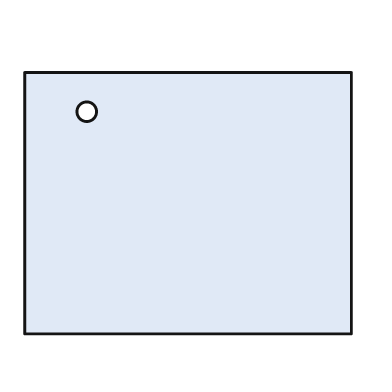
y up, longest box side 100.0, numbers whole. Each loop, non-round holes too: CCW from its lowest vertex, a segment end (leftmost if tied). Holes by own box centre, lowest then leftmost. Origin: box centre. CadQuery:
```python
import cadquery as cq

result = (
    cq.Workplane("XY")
    .moveTo(-50.0, -40.0)
    .lineTo(50.0, -40.0)
    .lineTo(50.0, 40.0)
    .lineTo(-50.0, 40.0)
    .close()
    .moveTo(-31.0, 28.0)
    .circle(3.0)
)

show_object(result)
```